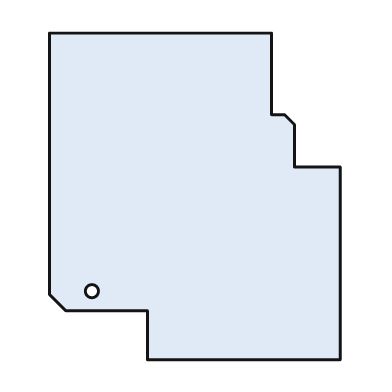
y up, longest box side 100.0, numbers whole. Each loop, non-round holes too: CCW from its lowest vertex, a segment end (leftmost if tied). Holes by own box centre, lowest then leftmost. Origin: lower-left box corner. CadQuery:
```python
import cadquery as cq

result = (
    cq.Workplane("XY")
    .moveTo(30.0, 0.0)
    .lineTo(89.0, 0.0)
    .lineTo(89.0, 59.0)
    .lineTo(75.0, 59.0)
    .lineTo(75.0, 72.0)
    .lineTo(72.0, 75.0)
    .lineTo(68.0, 75.0)
    .lineTo(68.0, 100.0)
    .lineTo(0.0, 100.0)
    .lineTo(0.0, 20.0)
    .lineTo(5.0, 15.0)
    .lineTo(30.0, 15.0)
    .close()
    .moveTo(13.0, 21.0)
    .circle(2.0)
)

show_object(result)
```